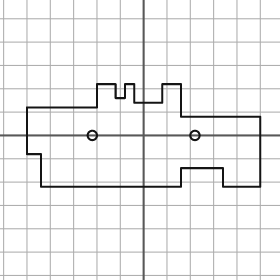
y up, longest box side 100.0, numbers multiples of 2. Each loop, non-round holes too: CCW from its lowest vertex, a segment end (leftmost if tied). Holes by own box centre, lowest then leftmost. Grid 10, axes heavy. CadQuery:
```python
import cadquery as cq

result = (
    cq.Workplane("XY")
    .moveTo(-44.0, -22.0)
    .lineTo(16.0, -22.0)
    .lineTo(16.0, -14.0)
    .lineTo(34.0, -14.0)
    .lineTo(34.0, -22.0)
    .lineTo(50.0, -22.0)
    .lineTo(50.0, 8.0)
    .lineTo(16.0, 8.0)
    .lineTo(16.0, 22.0)
    .lineTo(8.0, 22.0)
    .lineTo(8.0, 14.0)
    .lineTo(-4.0, 14.0)
    .lineTo(-4.0, 22.0)
    .lineTo(-8.0, 22.0)
    .lineTo(-8.0, 16.0)
    .lineTo(-12.0, 16.0)
    .lineTo(-12.0, 22.0)
    .lineTo(-20.0, 22.0)
    .lineTo(-20.0, 12.0)
    .lineTo(-50.0, 12.0)
    .lineTo(-50.0, -8.0)
    .lineTo(-44.0, -8.0)
    .close()
    .moveTo(-22.0, 0.0)
    .circle(2.0)
    .moveTo(22.0, 0.0)
    .circle(2.0)
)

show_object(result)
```